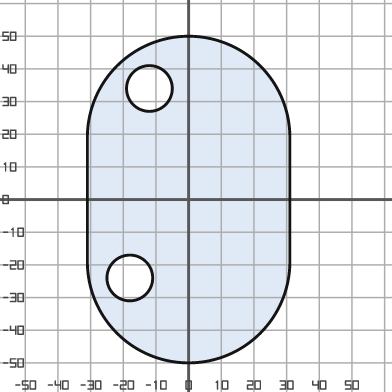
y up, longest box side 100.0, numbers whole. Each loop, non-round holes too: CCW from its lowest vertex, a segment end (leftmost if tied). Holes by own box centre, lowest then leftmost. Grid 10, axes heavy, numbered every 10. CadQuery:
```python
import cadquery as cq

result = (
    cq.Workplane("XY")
    .moveTo(-31.0, -19.0)
    .threePointArc((0.0, -50.0), (31.0, -19.0))
    .lineTo(31.0, 19.0)
    .threePointArc((0.0, 50.0), (-31.0, 19.0))
    .close()
    .moveTo(-18.0, -24.0)
    .circle(7.0)
    .moveTo(-12.0, 34.0)
    .circle(7.0)
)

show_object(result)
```